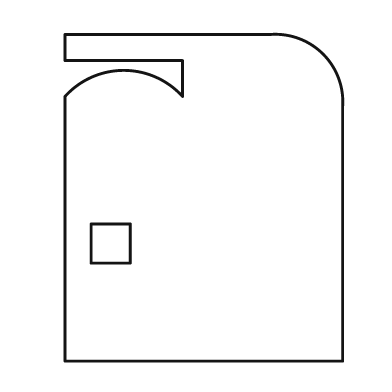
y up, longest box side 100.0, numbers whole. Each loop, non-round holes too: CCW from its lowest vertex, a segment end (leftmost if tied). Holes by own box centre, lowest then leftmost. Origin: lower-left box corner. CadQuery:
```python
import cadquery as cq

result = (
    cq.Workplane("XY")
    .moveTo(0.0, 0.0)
    .lineTo(85.0, 0.0)
    .lineTo(85.0, 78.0)
    .threePointArc((79.0, 94.0), (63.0, 100.0))
    .lineTo(0.0, 100.0)
    .lineTo(0.0, 92.0)
    .lineTo(36.0, 92.0)
    .lineTo(36.0, 81.0)
    .threePointArc((18.0, 89.0), (0.0, 81.0))
    .close()
    .moveTo(8.0, 30.0)
    .lineTo(20.0, 30.0)
    .lineTo(20.0, 42.0)
    .lineTo(8.0, 42.0)
    .close()
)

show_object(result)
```